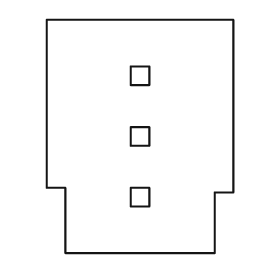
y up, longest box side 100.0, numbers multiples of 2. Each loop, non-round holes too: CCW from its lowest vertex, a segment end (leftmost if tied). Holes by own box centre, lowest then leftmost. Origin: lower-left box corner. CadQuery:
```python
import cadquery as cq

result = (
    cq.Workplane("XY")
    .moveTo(8.0, 0.0)
    .lineTo(72.0, 0.0)
    .lineTo(72.0, 26.0)
    .lineTo(80.0, 26.0)
    .lineTo(80.0, 100.0)
    .lineTo(0.0, 100.0)
    .lineTo(0.0, 28.0)
    .lineTo(8.0, 28.0)
    .close()
    .moveTo(36.0, 20.0)
    .lineTo(44.0, 20.0)
    .lineTo(44.0, 28.0)
    .lineTo(36.0, 28.0)
    .close()
    .moveTo(36.0, 46.0)
    .lineTo(44.0, 46.0)
    .lineTo(44.0, 54.0)
    .lineTo(36.0, 54.0)
    .close()
    .moveTo(36.0, 72.0)
    .lineTo(44.0, 72.0)
    .lineTo(44.0, 80.0)
    .lineTo(36.0, 80.0)
    .close()
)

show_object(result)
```